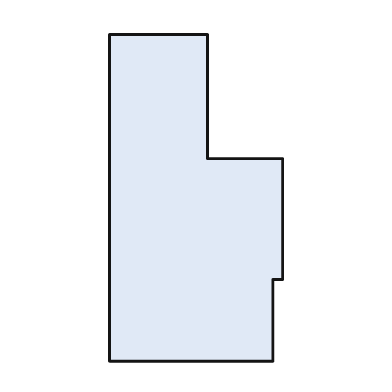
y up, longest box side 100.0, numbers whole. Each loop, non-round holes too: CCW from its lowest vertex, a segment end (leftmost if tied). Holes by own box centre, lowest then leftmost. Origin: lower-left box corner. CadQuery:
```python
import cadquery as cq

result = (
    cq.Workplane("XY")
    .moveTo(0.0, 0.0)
    .lineTo(50.0, 0.0)
    .lineTo(50.0, 25.0)
    .lineTo(53.0, 25.0)
    .lineTo(53.0, 62.0)
    .lineTo(30.0, 62.0)
    .lineTo(30.0, 100.0)
    .lineTo(0.0, 100.0)
    .close()
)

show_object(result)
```